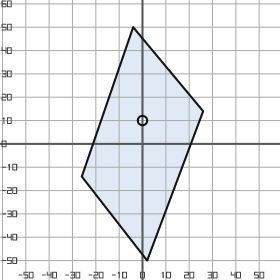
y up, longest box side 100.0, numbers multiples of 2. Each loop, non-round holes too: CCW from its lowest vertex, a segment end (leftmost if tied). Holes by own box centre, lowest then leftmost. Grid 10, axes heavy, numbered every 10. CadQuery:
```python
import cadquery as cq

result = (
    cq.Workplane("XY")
    .moveTo(2.0, -50.0)
    .lineTo(26.0, 14.0)
    .lineTo(-4.0, 50.0)
    .lineTo(-26.0, -14.0)
    .close()
    .moveTo(0.0, 10.0)
    .circle(2.0)
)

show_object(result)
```